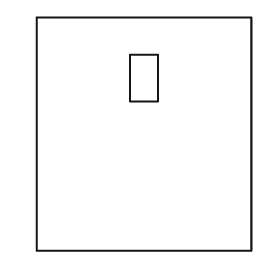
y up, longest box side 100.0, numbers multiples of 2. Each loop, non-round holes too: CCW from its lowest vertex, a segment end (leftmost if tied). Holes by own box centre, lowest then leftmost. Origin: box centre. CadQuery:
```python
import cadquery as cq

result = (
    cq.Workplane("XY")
    .moveTo(-46.0, -50.0)
    .lineTo(46.0, -50.0)
    .lineTo(46.0, 50.0)
    .lineTo(-46.0, 50.0)
    .close()
    .moveTo(-6.0, 14.0)
    .lineTo(6.0, 14.0)
    .lineTo(6.0, 34.0)
    .lineTo(-6.0, 34.0)
    .close()
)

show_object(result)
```